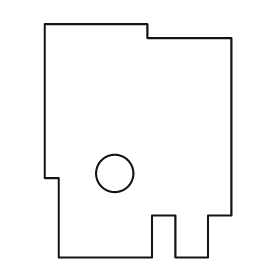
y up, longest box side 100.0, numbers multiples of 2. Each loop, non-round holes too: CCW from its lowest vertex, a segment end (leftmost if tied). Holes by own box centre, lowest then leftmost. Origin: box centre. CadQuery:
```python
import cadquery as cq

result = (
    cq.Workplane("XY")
    .moveTo(-34.0, -50.0)
    .lineTo(6.0, -50.0)
    .lineTo(6.0, -32.0)
    .lineTo(16.0, -32.0)
    .lineTo(16.0, -50.0)
    .lineTo(30.0, -50.0)
    .lineTo(30.0, -32.0)
    .lineTo(40.0, -32.0)
    .lineTo(40.0, 44.0)
    .lineTo(4.0, 44.0)
    .lineTo(4.0, 50.0)
    .lineTo(-40.0, 50.0)
    .lineTo(-40.0, -16.0)
    .lineTo(-34.0, -16.0)
    .close()
    .moveTo(-10.0, -14.0)
    .circle(8.0)
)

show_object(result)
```